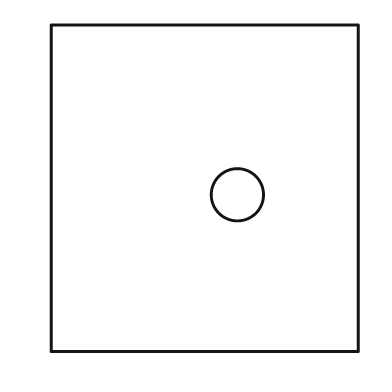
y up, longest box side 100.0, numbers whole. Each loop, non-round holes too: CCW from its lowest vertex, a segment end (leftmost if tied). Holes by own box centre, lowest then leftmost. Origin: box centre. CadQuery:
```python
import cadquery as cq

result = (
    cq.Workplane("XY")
    .moveTo(-47.0, -50.0)
    .lineTo(47.0, -50.0)
    .lineTo(47.0, 50.0)
    .lineTo(-47.0, 50.0)
    .close()
    .moveTo(10.0, -2.0)
    .circle(8.0)
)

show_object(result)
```